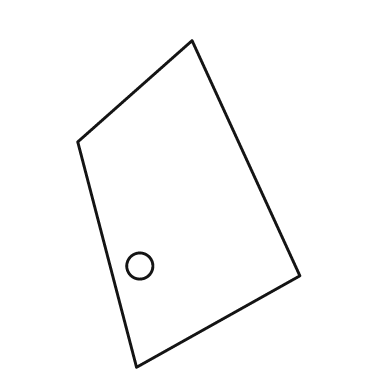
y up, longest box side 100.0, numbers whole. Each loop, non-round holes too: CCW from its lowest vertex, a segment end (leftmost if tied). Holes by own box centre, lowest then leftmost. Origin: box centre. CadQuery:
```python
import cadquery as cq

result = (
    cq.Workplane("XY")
    .moveTo(-16.0, -50.0)
    .lineTo(34.0, -22.0)
    .lineTo(1.0, 50.0)
    .lineTo(-34.0, 19.0)
    .close()
    .moveTo(-15.0, -19.0)
    .circle(4.0)
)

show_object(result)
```